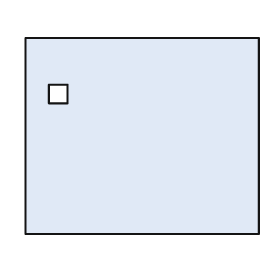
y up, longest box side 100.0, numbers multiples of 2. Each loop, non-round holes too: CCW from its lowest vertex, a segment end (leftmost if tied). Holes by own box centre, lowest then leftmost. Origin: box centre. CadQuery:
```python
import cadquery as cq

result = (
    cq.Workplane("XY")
    .moveTo(-50.0, -42.0)
    .lineTo(50.0, -42.0)
    .lineTo(50.0, 42.0)
    .lineTo(-50.0, 42.0)
    .close()
    .moveTo(-40.0, 14.0)
    .lineTo(-32.0, 14.0)
    .lineTo(-32.0, 22.0)
    .lineTo(-40.0, 22.0)
    .close()
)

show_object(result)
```